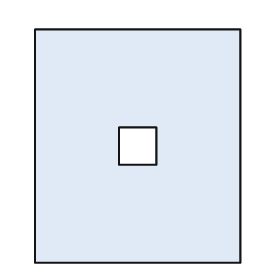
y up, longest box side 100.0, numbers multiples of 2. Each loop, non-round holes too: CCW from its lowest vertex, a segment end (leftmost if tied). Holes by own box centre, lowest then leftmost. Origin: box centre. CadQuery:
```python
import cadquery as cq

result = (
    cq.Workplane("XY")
    .moveTo(-44.0, -50.0)
    .lineTo(44.0, -50.0)
    .lineTo(44.0, 50.0)
    .lineTo(-44.0, 50.0)
    .close()
    .moveTo(-8.0, -8.0)
    .lineTo(8.0, -8.0)
    .lineTo(8.0, 8.0)
    .lineTo(-8.0, 8.0)
    .close()
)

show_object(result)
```